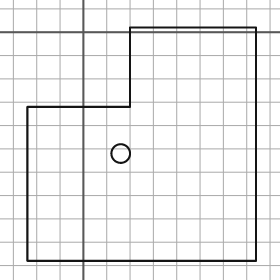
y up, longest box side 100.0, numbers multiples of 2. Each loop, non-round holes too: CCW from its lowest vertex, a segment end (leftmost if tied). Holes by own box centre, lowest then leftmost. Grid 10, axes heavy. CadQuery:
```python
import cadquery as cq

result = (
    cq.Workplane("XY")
    .moveTo(-24.0, -98.0)
    .lineTo(74.0, -98.0)
    .lineTo(74.0, 2.0)
    .lineTo(20.0, 2.0)
    .lineTo(20.0, -32.0)
    .lineTo(-24.0, -32.0)
    .close()
    .moveTo(16.0, -52.0)
    .circle(4.0)
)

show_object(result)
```